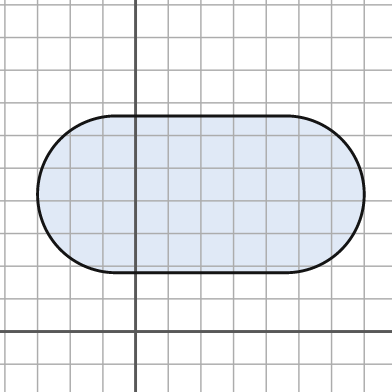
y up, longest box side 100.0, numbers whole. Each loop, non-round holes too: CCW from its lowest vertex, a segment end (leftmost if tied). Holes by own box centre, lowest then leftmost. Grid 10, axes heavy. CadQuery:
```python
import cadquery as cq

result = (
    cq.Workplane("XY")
    .moveTo(-6.0, 18.0)
    .lineTo(46.0, 18.0)
    .threePointArc((70.0, 42.0), (46.0, 66.0))
    .lineTo(-6.0, 66.0)
    .threePointArc((-30.0, 42.0), (-6.0, 18.0))
    .close()
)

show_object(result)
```